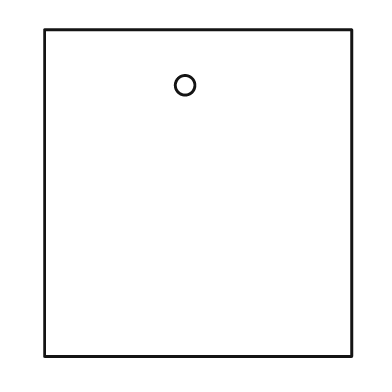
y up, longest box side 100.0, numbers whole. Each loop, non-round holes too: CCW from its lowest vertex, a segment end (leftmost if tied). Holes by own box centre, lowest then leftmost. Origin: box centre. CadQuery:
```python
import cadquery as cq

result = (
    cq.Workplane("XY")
    .moveTo(-47.0, -50.0)
    .lineTo(47.0, -50.0)
    .lineTo(47.0, 50.0)
    .lineTo(-47.0, 50.0)
    .close()
    .moveTo(-4.0, 33.0)
    .circle(3.0)
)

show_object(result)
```